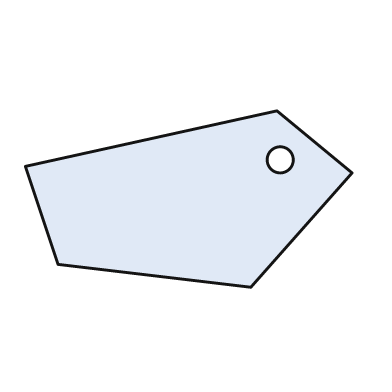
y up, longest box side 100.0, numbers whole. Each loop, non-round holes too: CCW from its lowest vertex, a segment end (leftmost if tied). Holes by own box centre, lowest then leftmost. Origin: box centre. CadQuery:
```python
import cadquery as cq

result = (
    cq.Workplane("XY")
    .moveTo(19.0, -27.0)
    .lineTo(50.0, 8.0)
    .lineTo(27.0, 27.0)
    .lineTo(-50.0, 10.0)
    .lineTo(-40.0, -20.0)
    .close()
    .moveTo(28.0, 12.0)
    .circle(4.0)
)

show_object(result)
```